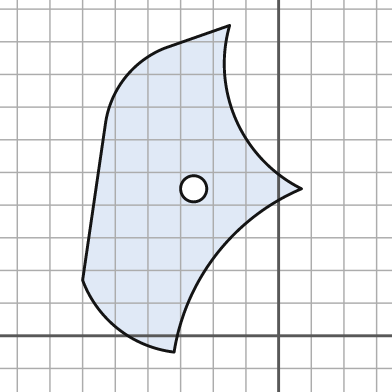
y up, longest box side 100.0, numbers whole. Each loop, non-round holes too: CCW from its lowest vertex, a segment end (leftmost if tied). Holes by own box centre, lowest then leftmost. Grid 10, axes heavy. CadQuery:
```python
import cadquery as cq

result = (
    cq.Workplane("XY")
    .moveTo(-32.0, -5.0)
    .threePointArc((-19.0, 25.0), (7.0, 45.0))
    .threePointArc((-13.0, 66.0), (-15.0, 95.0))
    .lineTo(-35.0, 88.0)
    .threePointArc((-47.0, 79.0), (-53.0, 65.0))
    .lineTo(-60.0, 17.0)
    .threePointArc((-49.0, 2.0), (-32.0, -5.0))
    .close()
    .moveTo(-26.0, 45.0)
    .circle(4.0)
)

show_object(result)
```